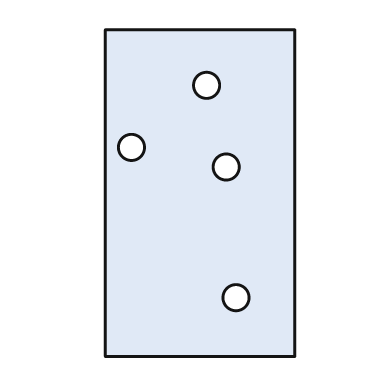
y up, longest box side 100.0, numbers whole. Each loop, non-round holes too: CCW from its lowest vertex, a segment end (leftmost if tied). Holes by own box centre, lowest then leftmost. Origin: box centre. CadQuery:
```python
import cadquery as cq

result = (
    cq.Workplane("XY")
    .moveTo(-29.0, -50.0)
    .lineTo(29.0, -50.0)
    .lineTo(29.0, 50.0)
    .lineTo(-29.0, 50.0)
    .close()
    .moveTo(11.0, -32.0)
    .circle(4.0)
    .moveTo(8.0, 8.0)
    .circle(4.0)
    .moveTo(-21.0, 14.0)
    .circle(4.0)
    .moveTo(2.0, 33.0)
    .circle(4.0)
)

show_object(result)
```